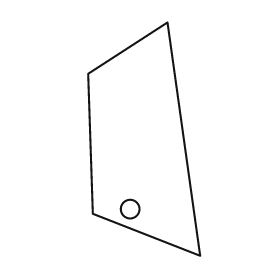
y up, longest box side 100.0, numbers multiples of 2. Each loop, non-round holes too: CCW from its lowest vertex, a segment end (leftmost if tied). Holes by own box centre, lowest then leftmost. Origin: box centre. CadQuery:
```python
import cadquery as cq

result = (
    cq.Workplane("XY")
    .moveTo(24.0, -50.0)
    .lineTo(10.0, 50.0)
    .lineTo(-24.0, 28.0)
    .lineTo(-22.0, -32.0)
    .close()
    .moveTo(-6.0, -30.0)
    .circle(4.0)
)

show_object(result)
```